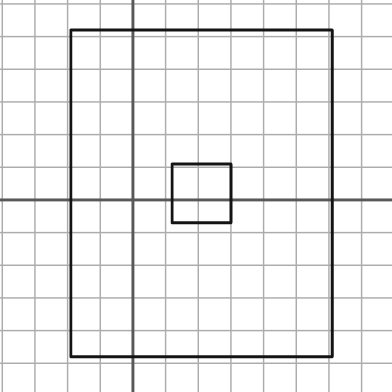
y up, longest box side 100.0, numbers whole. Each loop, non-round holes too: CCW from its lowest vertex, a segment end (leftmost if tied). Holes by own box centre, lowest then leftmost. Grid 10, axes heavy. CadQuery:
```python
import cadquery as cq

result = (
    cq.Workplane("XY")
    .moveTo(-19.0, -48.0)
    .lineTo(61.0, -48.0)
    .lineTo(61.0, 52.0)
    .lineTo(-19.0, 52.0)
    .close()
    .moveTo(12.0, -7.0)
    .lineTo(30.0, -7.0)
    .lineTo(30.0, 11.0)
    .lineTo(12.0, 11.0)
    .close()
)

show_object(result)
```